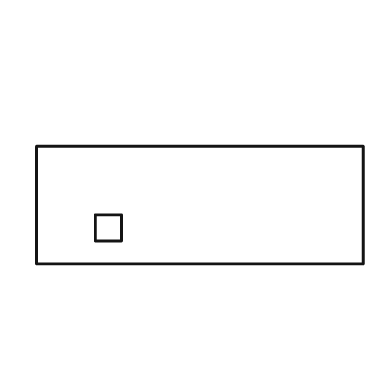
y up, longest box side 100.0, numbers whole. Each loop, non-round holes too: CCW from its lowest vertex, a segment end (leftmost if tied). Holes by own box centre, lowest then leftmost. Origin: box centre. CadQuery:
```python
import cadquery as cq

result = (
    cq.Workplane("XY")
    .moveTo(-50.0, -18.0)
    .lineTo(50.0, -18.0)
    .lineTo(50.0, 18.0)
    .lineTo(-50.0, 18.0)
    .close()
    .moveTo(-32.0, -11.0)
    .lineTo(-24.0, -11.0)
    .lineTo(-24.0, -3.0)
    .lineTo(-32.0, -3.0)
    .close()
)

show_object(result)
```